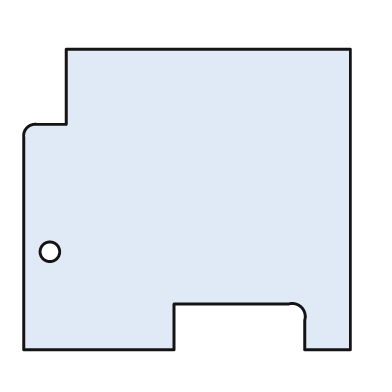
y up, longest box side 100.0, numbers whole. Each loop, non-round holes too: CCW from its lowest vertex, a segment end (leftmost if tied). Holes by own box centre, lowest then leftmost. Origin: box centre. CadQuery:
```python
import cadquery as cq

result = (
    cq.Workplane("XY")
    .moveTo(-50.0, -46.0)
    .lineTo(-4.0, -46.0)
    .lineTo(-4.0, -32.0)
    .lineTo(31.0, -32.0)
    .threePointArc((35.0, -33.0), (36.0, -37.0))
    .lineTo(36.0, -46.0)
    .lineTo(50.0, -46.0)
    .lineTo(50.0, 46.0)
    .lineTo(-37.0, 46.0)
    .lineTo(-37.0, 23.0)
    .lineTo(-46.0, 23.0)
    .threePointArc((-49.0, 22.0), (-50.0, 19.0))
    .close()
    .moveTo(-42.0, -16.0)
    .circle(3.0)
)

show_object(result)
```